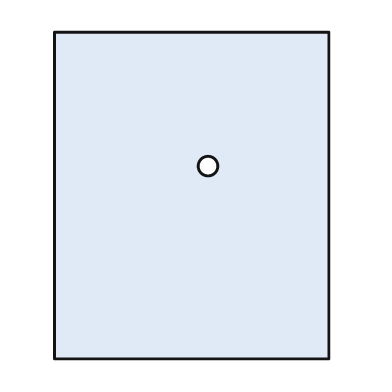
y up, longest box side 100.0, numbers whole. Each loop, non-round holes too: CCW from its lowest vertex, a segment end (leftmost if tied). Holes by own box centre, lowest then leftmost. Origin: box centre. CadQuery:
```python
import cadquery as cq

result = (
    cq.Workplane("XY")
    .moveTo(-42.0, -50.0)
    .lineTo(42.0, -50.0)
    .lineTo(42.0, 50.0)
    .lineTo(-42.0, 50.0)
    .close()
    .moveTo(5.0, 9.0)
    .circle(3.0)
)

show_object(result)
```